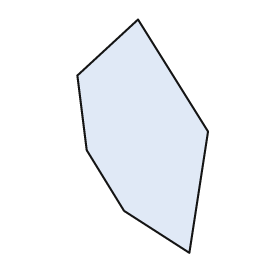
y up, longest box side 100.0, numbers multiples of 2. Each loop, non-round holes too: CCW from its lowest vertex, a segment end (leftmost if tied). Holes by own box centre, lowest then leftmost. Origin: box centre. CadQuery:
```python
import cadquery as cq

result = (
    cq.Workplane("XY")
    .moveTo(20.0, -50.0)
    .lineTo(28.0, 2.0)
    .lineTo(-2.0, 50.0)
    .lineTo(-28.0, 26.0)
    .lineTo(-24.0, -6.0)
    .lineTo(-8.0, -32.0)
    .close()
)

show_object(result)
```